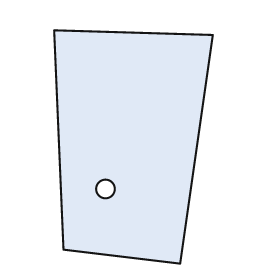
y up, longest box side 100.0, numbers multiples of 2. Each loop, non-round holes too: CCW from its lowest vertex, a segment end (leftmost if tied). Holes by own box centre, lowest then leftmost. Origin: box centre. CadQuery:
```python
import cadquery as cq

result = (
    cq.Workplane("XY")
    .moveTo(20.0, -50.0)
    .lineTo(34.0, 48.0)
    .lineTo(-34.0, 50.0)
    .lineTo(-30.0, -44.0)
    .close()
    .moveTo(-12.0, -18.0)
    .circle(4.0)
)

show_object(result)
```